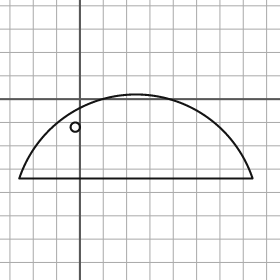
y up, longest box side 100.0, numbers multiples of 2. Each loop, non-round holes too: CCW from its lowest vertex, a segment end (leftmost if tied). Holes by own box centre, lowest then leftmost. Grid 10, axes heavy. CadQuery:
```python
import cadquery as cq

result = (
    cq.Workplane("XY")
    .moveTo(-26.0, -34.0)
    .lineTo(74.0, -34.0)
    .threePointArc((24.0, 2.0), (-26.0, -34.0))
    .close()
    .moveTo(-2.0, -12.0)
    .circle(2.0)
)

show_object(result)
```